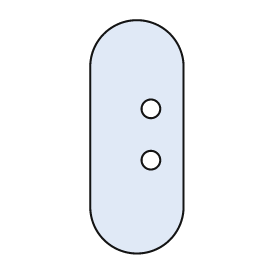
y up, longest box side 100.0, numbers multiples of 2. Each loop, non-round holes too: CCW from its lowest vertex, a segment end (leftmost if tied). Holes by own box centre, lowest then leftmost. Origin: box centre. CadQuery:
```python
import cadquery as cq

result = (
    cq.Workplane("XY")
    .moveTo(-20.0, -30.0)
    .threePointArc((0.0, -50.0), (20.0, -30.0))
    .lineTo(20.0, 30.0)
    .threePointArc((0.0, 50.0), (-20.0, 30.0))
    .close()
    .moveTo(6.0, -10.0)
    .circle(4.0)
    .moveTo(6.0, 12.0)
    .circle(4.0)
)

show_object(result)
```